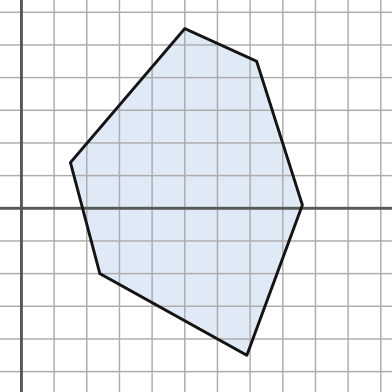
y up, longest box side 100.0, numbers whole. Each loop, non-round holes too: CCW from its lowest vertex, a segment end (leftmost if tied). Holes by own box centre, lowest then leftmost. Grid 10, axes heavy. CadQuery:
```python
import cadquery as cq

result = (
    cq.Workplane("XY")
    .moveTo(69.0, -45.0)
    .lineTo(86.0, 1.0)
    .lineTo(72.0, 45.0)
    .lineTo(50.0, 55.0)
    .lineTo(15.0, 14.0)
    .lineTo(24.0, -20.0)
    .close()
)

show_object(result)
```